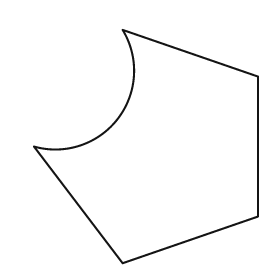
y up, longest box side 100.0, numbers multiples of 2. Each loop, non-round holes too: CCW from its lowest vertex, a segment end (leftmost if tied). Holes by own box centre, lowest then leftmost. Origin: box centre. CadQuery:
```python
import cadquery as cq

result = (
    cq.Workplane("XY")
    .moveTo(-10.0, -50.0)
    .lineTo(48.0, -30.0)
    .lineTo(48.0, 30.0)
    .lineTo(-10.0, 50.0)
    .threePointArc((-12.0, 12.0), (-48.0, 0.0))
    .close()
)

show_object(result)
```